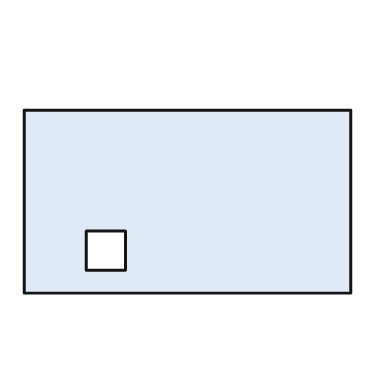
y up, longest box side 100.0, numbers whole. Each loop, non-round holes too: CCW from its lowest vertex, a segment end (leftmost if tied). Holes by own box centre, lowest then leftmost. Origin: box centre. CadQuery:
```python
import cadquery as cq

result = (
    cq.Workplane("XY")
    .moveTo(-50.0, -28.0)
    .lineTo(50.0, -28.0)
    .lineTo(50.0, 28.0)
    .lineTo(-50.0, 28.0)
    .close()
    .moveTo(-31.0, -21.0)
    .lineTo(-19.0, -21.0)
    .lineTo(-19.0, -9.0)
    .lineTo(-31.0, -9.0)
    .close()
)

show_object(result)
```